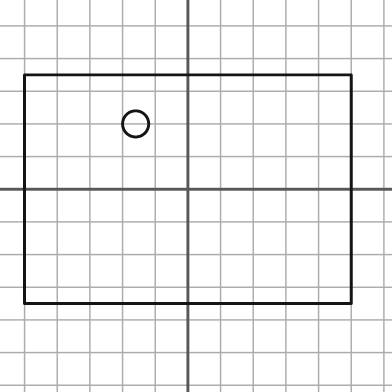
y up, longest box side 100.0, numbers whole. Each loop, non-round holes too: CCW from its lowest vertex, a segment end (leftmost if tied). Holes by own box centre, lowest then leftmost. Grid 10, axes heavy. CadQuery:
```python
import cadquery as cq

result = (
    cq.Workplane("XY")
    .moveTo(-50.0, -35.0)
    .lineTo(50.0, -35.0)
    .lineTo(50.0, 35.0)
    .lineTo(-50.0, 35.0)
    .close()
    .moveTo(-16.0, 20.0)
    .circle(4.0)
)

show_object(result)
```